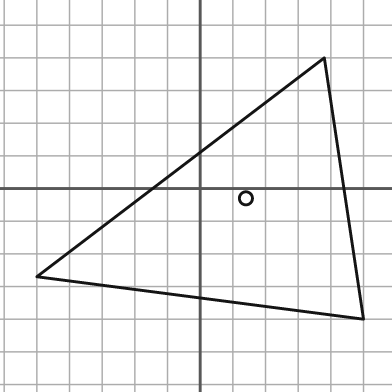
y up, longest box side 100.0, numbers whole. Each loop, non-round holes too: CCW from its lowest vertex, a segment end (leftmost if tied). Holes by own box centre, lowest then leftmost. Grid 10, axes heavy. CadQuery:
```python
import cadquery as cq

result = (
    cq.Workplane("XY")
    .moveTo(50.0, -40.0)
    .lineTo(38.0, 40.0)
    .lineTo(-50.0, -27.0)
    .close()
    .moveTo(14.0, -3.0)
    .circle(2.0)
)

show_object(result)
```